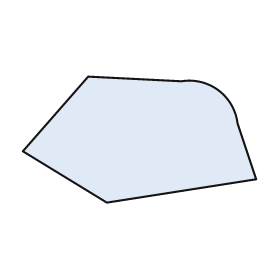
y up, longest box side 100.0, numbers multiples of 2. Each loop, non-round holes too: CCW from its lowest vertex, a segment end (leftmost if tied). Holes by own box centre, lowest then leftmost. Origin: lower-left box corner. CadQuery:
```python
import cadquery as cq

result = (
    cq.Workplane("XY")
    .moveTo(36.0, 0.0)
    .lineTo(100.0, 10.0)
    .lineTo(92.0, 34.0)
    .threePointArc((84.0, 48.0), (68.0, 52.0))
    .lineTo(28.0, 54.0)
    .lineTo(0.0, 22.0)
    .close()
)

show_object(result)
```